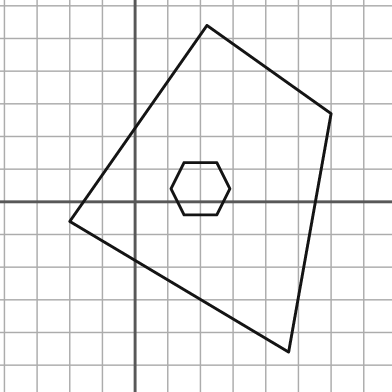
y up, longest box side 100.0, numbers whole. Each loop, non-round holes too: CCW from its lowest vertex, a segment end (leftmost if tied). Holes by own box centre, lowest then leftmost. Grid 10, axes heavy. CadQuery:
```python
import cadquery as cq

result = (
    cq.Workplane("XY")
    .moveTo(47.0, -46.0)
    .lineTo(60.0, 27.0)
    .lineTo(22.0, 54.0)
    .lineTo(-20.0, -6.0)
    .close()
    .moveTo(15.0, -4.0)
    .lineTo(25.0, -4.0)
    .lineTo(29.0, 4.0)
    .lineTo(25.0, 12.0)
    .lineTo(15.0, 12.0)
    .lineTo(11.0, 4.0)
    .close()
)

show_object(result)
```